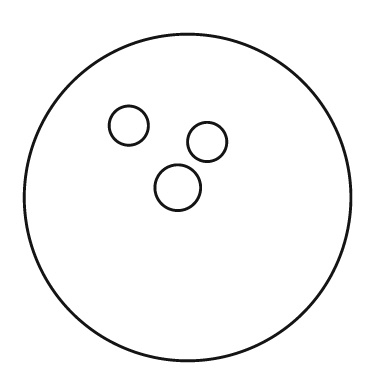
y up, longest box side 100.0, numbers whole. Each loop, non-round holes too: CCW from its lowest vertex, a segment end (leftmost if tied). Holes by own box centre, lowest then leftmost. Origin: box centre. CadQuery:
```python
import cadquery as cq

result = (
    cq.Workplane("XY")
    .moveTo(0.0, 0.0)
    .circle(50.0)
    .moveTo(-3.0, 3.0)
    .circle(7.0)
    .moveTo(6.0, 17.0)
    .circle(6.0)
    .moveTo(-18.0, 22.0)
    .circle(6.0)
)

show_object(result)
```